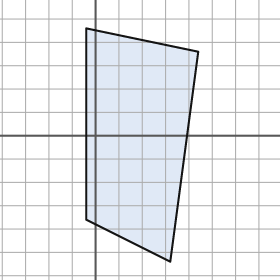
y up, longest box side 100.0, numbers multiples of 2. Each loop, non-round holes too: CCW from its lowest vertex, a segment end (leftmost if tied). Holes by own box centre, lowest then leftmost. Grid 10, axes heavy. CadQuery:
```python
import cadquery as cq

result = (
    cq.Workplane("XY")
    .moveTo(32.0, -54.0)
    .lineTo(44.0, 36.0)
    .lineTo(-4.0, 46.0)
    .lineTo(-4.0, -36.0)
    .close()
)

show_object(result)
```